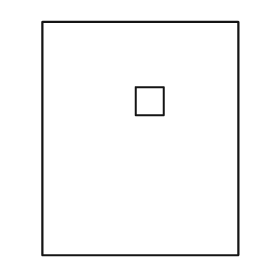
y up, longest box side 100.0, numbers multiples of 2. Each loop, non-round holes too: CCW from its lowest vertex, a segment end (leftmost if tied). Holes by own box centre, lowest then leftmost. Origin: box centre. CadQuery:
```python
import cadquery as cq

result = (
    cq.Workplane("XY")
    .moveTo(-42.0, -50.0)
    .lineTo(42.0, -50.0)
    .lineTo(42.0, 50.0)
    .lineTo(-42.0, 50.0)
    .close()
    .moveTo(-2.0, 10.0)
    .lineTo(10.0, 10.0)
    .lineTo(10.0, 22.0)
    .lineTo(-2.0, 22.0)
    .close()
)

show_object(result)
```